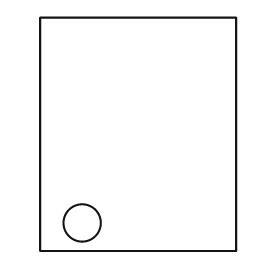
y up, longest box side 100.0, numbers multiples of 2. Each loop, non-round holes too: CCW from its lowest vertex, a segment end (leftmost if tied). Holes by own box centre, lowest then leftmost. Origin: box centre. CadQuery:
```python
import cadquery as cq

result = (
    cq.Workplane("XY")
    .moveTo(-42.0, -50.0)
    .lineTo(42.0, -50.0)
    .lineTo(42.0, 50.0)
    .lineTo(-42.0, 50.0)
    .close()
    .moveTo(-24.0, -38.0)
    .circle(8.0)
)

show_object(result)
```